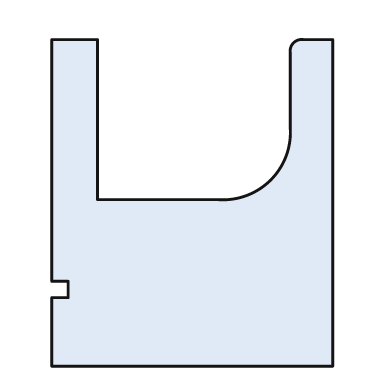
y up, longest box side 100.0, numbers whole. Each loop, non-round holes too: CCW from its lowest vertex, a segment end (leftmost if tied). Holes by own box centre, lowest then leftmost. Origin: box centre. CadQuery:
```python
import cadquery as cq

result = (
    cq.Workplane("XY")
    .moveTo(-43.0, -50.0)
    .lineTo(43.0, -50.0)
    .lineTo(43.0, 50.0)
    .lineTo(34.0, 50.0)
    .threePointArc((31.0, 49.0), (30.0, 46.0))
    .lineTo(30.0, 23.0)
    .threePointArc((24.0, 7.0), (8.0, 1.0))
    .lineTo(-29.0, 1.0)
    .lineTo(-29.0, 50.0)
    .lineTo(-43.0, 50.0)
    .lineTo(-43.0, -24.0)
    .lineTo(-38.0, -24.0)
    .lineTo(-38.0, -29.0)
    .lineTo(-43.0, -29.0)
    .close()
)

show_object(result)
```